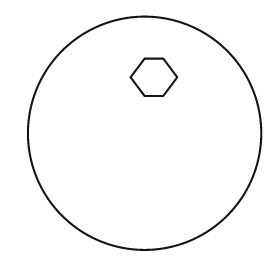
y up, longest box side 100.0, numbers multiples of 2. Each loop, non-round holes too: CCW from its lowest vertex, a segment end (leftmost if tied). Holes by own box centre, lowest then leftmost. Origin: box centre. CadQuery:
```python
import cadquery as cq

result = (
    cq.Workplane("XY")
    .moveTo(0.0, 0.0)
    .circle(50.0)
    .moveTo(0.0, 16.0)
    .lineTo(8.0, 16.0)
    .lineTo(14.0, 24.0)
    .lineTo(8.0, 32.0)
    .lineTo(0.0, 32.0)
    .lineTo(-6.0, 24.0)
    .close()
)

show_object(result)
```